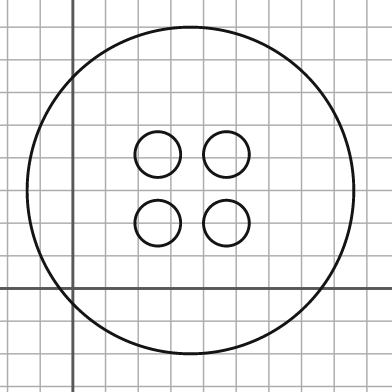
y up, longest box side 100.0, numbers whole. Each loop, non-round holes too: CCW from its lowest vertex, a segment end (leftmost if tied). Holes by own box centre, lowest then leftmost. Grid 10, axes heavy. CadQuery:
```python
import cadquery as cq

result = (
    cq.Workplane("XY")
    .moveTo(36.0, 30.0)
    .circle(50.0)
    .moveTo(26.0, 20.0)
    .circle(7.0)
    .moveTo(47.0, 20.0)
    .circle(7.0)
    .moveTo(26.0, 41.0)
    .circle(7.0)
    .moveTo(47.0, 41.0)
    .circle(7.0)
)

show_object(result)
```